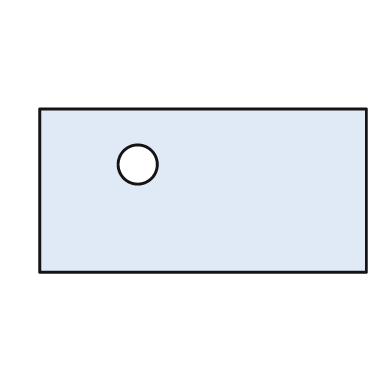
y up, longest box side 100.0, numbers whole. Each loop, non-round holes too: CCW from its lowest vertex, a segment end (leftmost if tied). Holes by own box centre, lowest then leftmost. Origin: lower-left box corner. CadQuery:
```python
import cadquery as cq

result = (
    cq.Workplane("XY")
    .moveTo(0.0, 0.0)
    .lineTo(100.0, 0.0)
    .lineTo(100.0, 50.0)
    .lineTo(0.0, 50.0)
    .close()
    .moveTo(30.0, 33.0)
    .circle(6.0)
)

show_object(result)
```